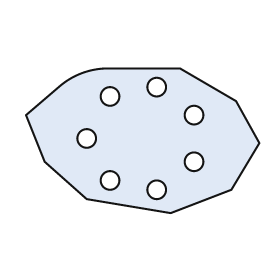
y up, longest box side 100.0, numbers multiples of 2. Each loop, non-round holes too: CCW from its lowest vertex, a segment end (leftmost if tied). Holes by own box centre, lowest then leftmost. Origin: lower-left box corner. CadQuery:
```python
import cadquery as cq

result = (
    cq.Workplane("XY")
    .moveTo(62.0, 0.0)
    .lineTo(88.0, 10.0)
    .lineTo(100.0, 30.0)
    .lineTo(90.0, 48.0)
    .lineTo(66.0, 62.0)
    .lineTo(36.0, 62.0)
    .threePointArc((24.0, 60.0), (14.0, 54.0))
    .lineTo(0.0, 42.0)
    .lineTo(8.0, 22.0)
    .lineTo(26.0, 6.0)
    .close()
    .moveTo(56.0, 10.0)
    .circle(4.0)
    .moveTo(36.0, 14.0)
    .circle(4.0)
    .moveTo(72.0, 22.0)
    .circle(4.0)
    .moveTo(26.0, 32.0)
    .circle(4.0)
    .moveTo(72.0, 42.0)
    .circle(4.0)
    .moveTo(36.0, 50.0)
    .circle(4.0)
    .moveTo(56.0, 54.0)
    .circle(4.0)
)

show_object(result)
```